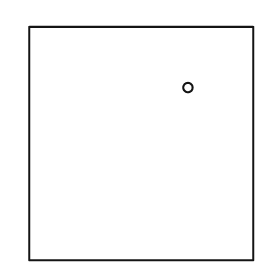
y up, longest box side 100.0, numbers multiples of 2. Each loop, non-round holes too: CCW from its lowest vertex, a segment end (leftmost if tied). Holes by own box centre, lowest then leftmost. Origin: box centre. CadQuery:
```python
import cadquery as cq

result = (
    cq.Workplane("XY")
    .moveTo(-48.0, -50.0)
    .lineTo(48.0, -50.0)
    .lineTo(48.0, 50.0)
    .lineTo(-48.0, 50.0)
    .close()
    .moveTo(20.0, 24.0)
    .circle(2.0)
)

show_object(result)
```